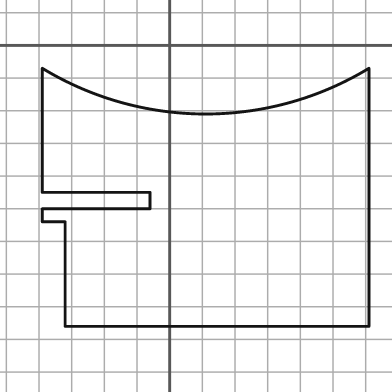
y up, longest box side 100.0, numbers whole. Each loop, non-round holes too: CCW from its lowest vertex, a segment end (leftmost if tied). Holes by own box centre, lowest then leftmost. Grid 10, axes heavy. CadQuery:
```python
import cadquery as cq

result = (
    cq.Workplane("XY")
    .moveTo(-32.0, -86.0)
    .lineTo(61.0, -86.0)
    .lineTo(61.0, -7.0)
    .threePointArc((11.0, -21.0), (-39.0, -7.0))
    .lineTo(-39.0, -45.0)
    .lineTo(-6.0, -45.0)
    .lineTo(-6.0, -50.0)
    .lineTo(-39.0, -50.0)
    .lineTo(-39.0, -54.0)
    .lineTo(-32.0, -54.0)
    .close()
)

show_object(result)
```